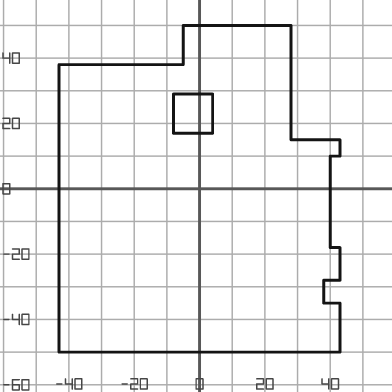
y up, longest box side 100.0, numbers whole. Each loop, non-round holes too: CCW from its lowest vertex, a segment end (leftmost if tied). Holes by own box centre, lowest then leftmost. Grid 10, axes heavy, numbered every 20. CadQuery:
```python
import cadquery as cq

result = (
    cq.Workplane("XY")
    .moveTo(-43.0, -50.0)
    .lineTo(43.0, -50.0)
    .lineTo(43.0, -35.0)
    .lineTo(38.0, -35.0)
    .lineTo(38.0, -28.0)
    .lineTo(43.0, -28.0)
    .lineTo(43.0, -18.0)
    .lineTo(40.0, -18.0)
    .lineTo(40.0, 10.0)
    .lineTo(43.0, 10.0)
    .lineTo(43.0, 15.0)
    .lineTo(28.0, 15.0)
    .lineTo(28.0, 50.0)
    .lineTo(-5.0, 50.0)
    .lineTo(-5.0, 38.0)
    .lineTo(-43.0, 38.0)
    .close()
    .moveTo(-8.0, 17.0)
    .lineTo(4.0, 17.0)
    .lineTo(4.0, 29.0)
    .lineTo(-8.0, 29.0)
    .close()
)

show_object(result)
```